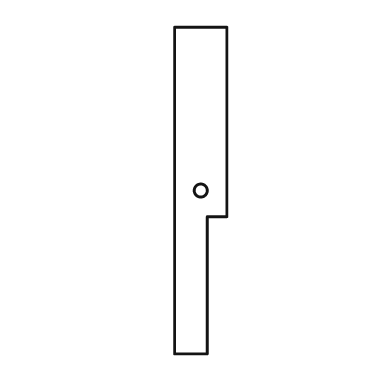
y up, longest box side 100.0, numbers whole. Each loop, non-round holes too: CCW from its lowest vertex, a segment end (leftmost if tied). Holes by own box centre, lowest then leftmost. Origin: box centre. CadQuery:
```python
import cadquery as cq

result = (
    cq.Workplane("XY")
    .moveTo(-8.0, -50.0)
    .lineTo(2.0, -50.0)
    .lineTo(2.0, -8.0)
    .lineTo(8.0, -8.0)
    .lineTo(8.0, 50.0)
    .lineTo(-8.0, 50.0)
    .close()
    .moveTo(0.0, 0.0)
    .circle(2.0)
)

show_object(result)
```